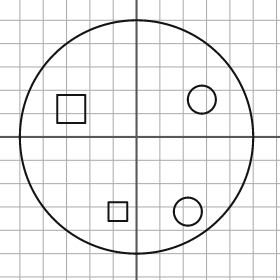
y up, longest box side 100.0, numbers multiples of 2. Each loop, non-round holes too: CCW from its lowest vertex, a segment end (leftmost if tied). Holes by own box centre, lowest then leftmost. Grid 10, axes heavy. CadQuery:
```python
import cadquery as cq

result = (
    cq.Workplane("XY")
    .moveTo(0.0, 0.0)
    .circle(50.0)
    .moveTo(-12.0, -36.0)
    .lineTo(-4.0, -36.0)
    .lineTo(-4.0, -28.0)
    .lineTo(-12.0, -28.0)
    .close()
    .moveTo(22.0, -32.0)
    .circle(6.0)
    .moveTo(-34.0, 6.0)
    .lineTo(-22.0, 6.0)
    .lineTo(-22.0, 18.0)
    .lineTo(-34.0, 18.0)
    .close()
    .moveTo(28.0, 16.0)
    .circle(6.0)
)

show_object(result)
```